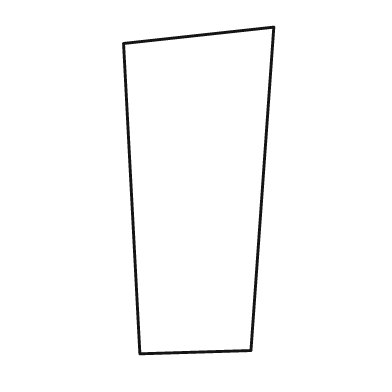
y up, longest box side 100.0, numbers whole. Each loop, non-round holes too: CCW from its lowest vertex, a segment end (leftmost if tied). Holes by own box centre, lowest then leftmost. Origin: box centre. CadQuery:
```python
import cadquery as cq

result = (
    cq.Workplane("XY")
    .moveTo(-18.0, -50.0)
    .lineTo(16.0, -49.0)
    .lineTo(23.0, 50.0)
    .lineTo(-23.0, 45.0)
    .close()
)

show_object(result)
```